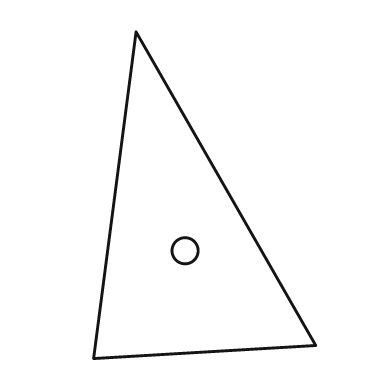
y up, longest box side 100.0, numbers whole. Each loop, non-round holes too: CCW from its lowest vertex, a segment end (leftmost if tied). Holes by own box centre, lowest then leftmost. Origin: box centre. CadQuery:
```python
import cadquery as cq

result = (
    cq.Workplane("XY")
    .moveTo(-34.0, -50.0)
    .lineTo(34.0, -46.0)
    .lineTo(-21.0, 50.0)
    .close()
    .moveTo(-6.0, -17.0)
    .circle(4.0)
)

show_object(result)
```